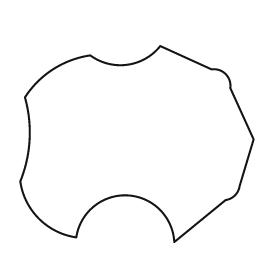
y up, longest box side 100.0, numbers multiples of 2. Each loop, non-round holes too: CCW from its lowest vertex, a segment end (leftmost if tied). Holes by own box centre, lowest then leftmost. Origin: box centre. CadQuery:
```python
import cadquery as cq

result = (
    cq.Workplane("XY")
    .moveTo(16.0, -42.0)
    .lineTo(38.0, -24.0)
    .threePointArc((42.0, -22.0), (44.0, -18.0))
    .lineTo(50.0, 2.0)
    .lineTo(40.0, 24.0)
    .threePointArc((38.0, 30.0), (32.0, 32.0))
    .lineTo(10.0, 42.0)
    .threePointArc((-4.0, 34.0), (-20.0, 38.0))
    .threePointArc((-36.0, 32.0), (-48.0, 20.0))
    .threePointArc((-46.0, 2.0), (-50.0, -16.0))
    .threePointArc((-42.0, -32.0), (-26.0, -40.0))
    .threePointArc((-4.0, -22.0), (16.0, -42.0))
    .close()
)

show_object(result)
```